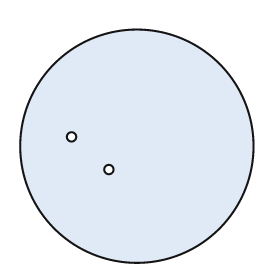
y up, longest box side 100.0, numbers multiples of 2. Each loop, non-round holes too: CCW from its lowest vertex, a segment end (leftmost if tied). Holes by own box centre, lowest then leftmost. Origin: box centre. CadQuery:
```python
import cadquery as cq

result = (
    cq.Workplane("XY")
    .moveTo(0.0, 0.0)
    .circle(50.0)
    .moveTo(-12.0, -10.0)
    .circle(2.0)
    .moveTo(-28.0, 4.0)
    .circle(2.0)
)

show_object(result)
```